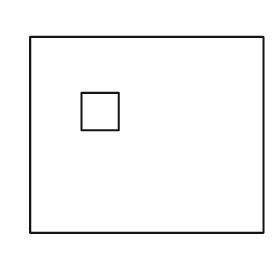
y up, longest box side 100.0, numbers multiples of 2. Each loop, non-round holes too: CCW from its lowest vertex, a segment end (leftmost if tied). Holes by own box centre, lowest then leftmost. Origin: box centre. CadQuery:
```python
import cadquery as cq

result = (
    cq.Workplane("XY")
    .moveTo(-50.0, -42.0)
    .lineTo(50.0, -42.0)
    .lineTo(50.0, 42.0)
    .lineTo(-50.0, 42.0)
    .close()
    .moveTo(-28.0, 2.0)
    .lineTo(-12.0, 2.0)
    .lineTo(-12.0, 18.0)
    .lineTo(-28.0, 18.0)
    .close()
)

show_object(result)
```